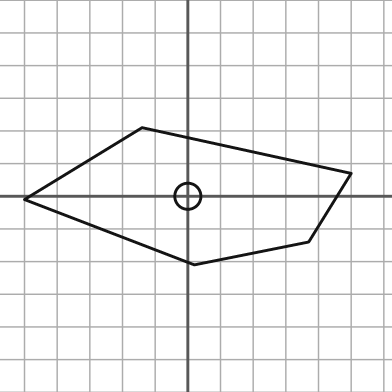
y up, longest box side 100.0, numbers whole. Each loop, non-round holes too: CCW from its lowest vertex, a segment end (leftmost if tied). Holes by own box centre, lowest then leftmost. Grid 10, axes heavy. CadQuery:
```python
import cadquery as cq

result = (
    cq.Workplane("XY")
    .moveTo(2.0, -21.0)
    .lineTo(37.0, -14.0)
    .lineTo(50.0, 7.0)
    .lineTo(-14.0, 21.0)
    .lineTo(-50.0, -1.0)
    .close()
    .moveTo(0.0, 0.0)
    .circle(4.0)
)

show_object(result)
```